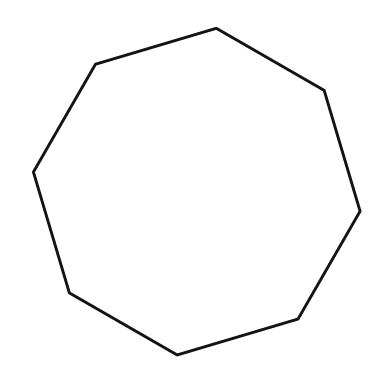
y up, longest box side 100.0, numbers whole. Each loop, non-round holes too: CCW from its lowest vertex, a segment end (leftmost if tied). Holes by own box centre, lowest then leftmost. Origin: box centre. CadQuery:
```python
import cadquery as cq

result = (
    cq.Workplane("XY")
    .moveTo(-6.0, -50.0)
    .lineTo(31.0, -39.0)
    .lineTo(50.0, -6.0)
    .lineTo(39.0, 31.0)
    .lineTo(6.0, 50.0)
    .lineTo(-31.0, 39.0)
    .lineTo(-50.0, 6.0)
    .lineTo(-39.0, -31.0)
    .close()
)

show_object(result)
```